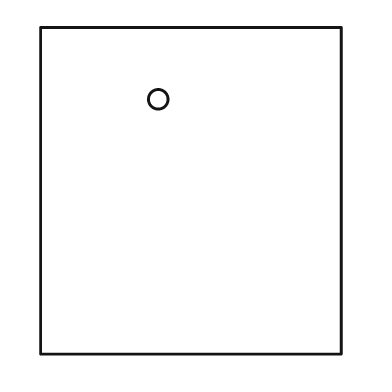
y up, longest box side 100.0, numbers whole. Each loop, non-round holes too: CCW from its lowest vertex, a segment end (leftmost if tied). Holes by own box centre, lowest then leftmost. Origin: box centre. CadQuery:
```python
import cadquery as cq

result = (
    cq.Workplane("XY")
    .moveTo(-46.0, -50.0)
    .lineTo(46.0, -50.0)
    .lineTo(46.0, 50.0)
    .lineTo(-46.0, 50.0)
    .close()
    .moveTo(-10.0, 28.0)
    .circle(3.0)
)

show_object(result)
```